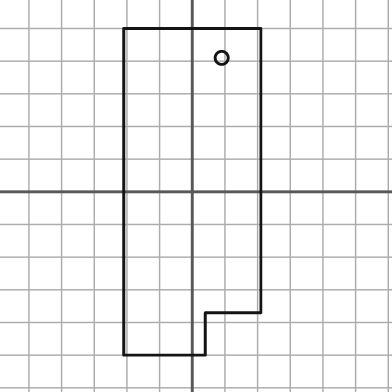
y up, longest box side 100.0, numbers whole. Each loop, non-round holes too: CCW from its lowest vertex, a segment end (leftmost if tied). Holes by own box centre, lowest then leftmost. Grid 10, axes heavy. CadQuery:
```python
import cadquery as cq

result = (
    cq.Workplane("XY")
    .moveTo(-21.0, -50.0)
    .lineTo(4.0, -50.0)
    .lineTo(4.0, -37.0)
    .lineTo(21.0, -37.0)
    .lineTo(21.0, 50.0)
    .lineTo(-21.0, 50.0)
    .close()
    .moveTo(9.0, 41.0)
    .circle(2.0)
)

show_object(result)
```